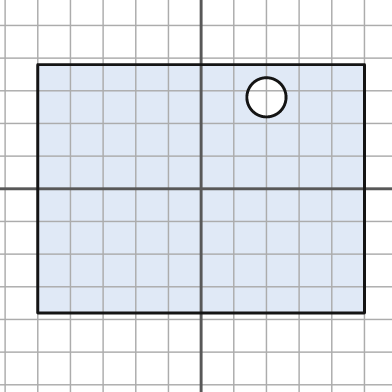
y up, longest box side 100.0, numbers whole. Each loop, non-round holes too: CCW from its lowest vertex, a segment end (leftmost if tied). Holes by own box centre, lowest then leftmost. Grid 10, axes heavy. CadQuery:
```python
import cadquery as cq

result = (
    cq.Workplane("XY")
    .moveTo(-50.0, -38.0)
    .lineTo(50.0, -38.0)
    .lineTo(50.0, 38.0)
    .lineTo(-50.0, 38.0)
    .close()
    .moveTo(20.0, 28.0)
    .circle(6.0)
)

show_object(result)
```